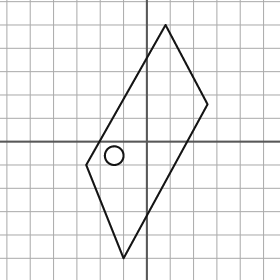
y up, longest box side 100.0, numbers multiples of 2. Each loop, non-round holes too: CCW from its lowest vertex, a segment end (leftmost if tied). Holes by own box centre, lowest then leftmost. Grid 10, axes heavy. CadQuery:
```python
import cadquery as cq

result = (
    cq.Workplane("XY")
    .moveTo(-10.0, -50.0)
    .lineTo(26.0, 16.0)
    .lineTo(8.0, 50.0)
    .lineTo(-26.0, -10.0)
    .close()
    .moveTo(-14.0, -6.0)
    .circle(4.0)
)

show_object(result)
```